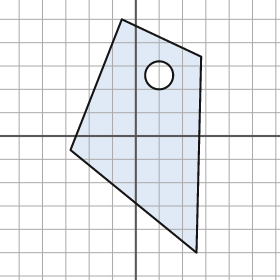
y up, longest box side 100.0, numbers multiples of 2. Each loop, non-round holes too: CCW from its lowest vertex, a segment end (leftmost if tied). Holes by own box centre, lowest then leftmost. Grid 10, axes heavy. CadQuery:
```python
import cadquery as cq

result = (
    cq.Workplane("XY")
    .moveTo(26.0, -50.0)
    .lineTo(28.0, 34.0)
    .lineTo(-6.0, 50.0)
    .lineTo(-28.0, -6.0)
    .close()
    .moveTo(10.0, 26.0)
    .circle(6.0)
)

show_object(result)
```